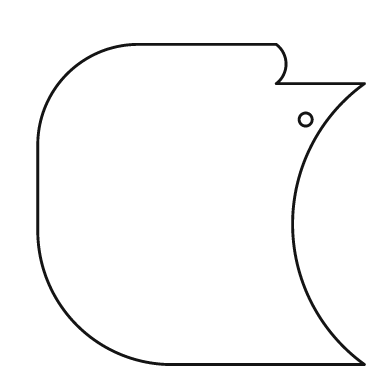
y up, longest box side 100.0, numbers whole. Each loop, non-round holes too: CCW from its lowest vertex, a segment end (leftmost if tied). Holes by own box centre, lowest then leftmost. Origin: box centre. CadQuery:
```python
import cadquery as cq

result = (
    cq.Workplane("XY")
    .moveTo(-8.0, -49.0)
    .lineTo(50.0, -49.0)
    .threePointArc((28.0, -6.0), (50.0, 37.0))
    .lineTo(23.0, 37.0)
    .threePointArc((26.0, 43.0), (23.0, 49.0))
    .lineTo(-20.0, 49.0)
    .threePointArc((-41.0, 40.0), (-50.0, 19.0))
    .lineTo(-50.0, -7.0)
    .threePointArc((-38.0, -37.0), (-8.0, -49.0))
    .close()
    .moveTo(32.0, 26.0)
    .circle(2.0)
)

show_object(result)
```